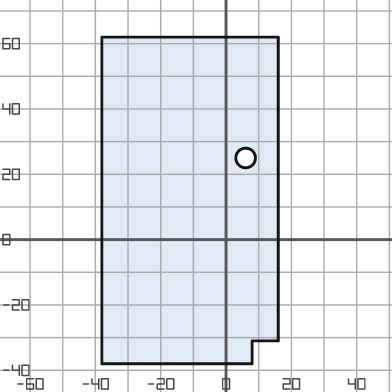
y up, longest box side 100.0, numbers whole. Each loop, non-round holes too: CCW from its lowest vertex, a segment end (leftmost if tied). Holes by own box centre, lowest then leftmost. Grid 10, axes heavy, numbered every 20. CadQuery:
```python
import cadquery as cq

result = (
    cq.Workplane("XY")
    .moveTo(-38.0, -38.0)
    .lineTo(8.0, -38.0)
    .lineTo(8.0, -31.0)
    .lineTo(16.0, -31.0)
    .lineTo(16.0, 62.0)
    .lineTo(-38.0, 62.0)
    .close()
    .moveTo(6.0, 25.0)
    .circle(3.0)
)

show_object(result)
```